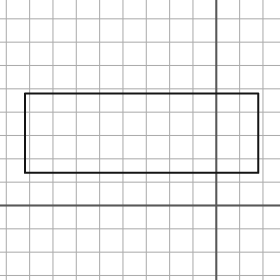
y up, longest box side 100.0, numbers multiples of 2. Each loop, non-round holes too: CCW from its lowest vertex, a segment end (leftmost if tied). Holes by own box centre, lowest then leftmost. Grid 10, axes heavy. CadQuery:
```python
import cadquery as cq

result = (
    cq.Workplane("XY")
    .moveTo(-82.0, 14.0)
    .lineTo(18.0, 14.0)
    .lineTo(18.0, 48.0)
    .lineTo(-82.0, 48.0)
    .close()
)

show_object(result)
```